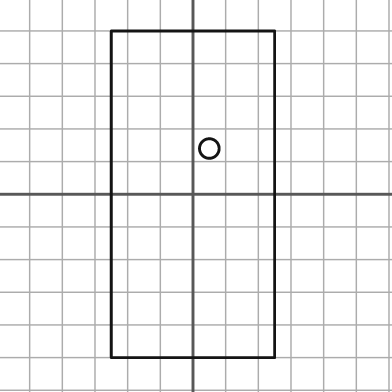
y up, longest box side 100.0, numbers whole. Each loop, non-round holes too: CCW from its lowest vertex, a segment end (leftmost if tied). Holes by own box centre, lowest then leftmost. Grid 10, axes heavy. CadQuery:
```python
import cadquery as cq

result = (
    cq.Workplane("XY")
    .moveTo(-25.0, -50.0)
    .lineTo(25.0, -50.0)
    .lineTo(25.0, 50.0)
    .lineTo(-25.0, 50.0)
    .close()
    .moveTo(5.0, 14.0)
    .circle(3.0)
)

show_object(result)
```